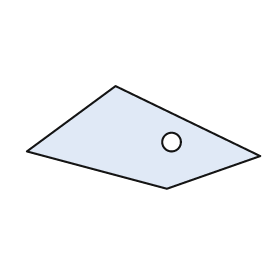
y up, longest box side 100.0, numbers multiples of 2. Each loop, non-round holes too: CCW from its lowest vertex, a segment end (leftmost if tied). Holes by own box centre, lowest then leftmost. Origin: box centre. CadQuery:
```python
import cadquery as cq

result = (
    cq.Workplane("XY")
    .moveTo(10.0, -22.0)
    .lineTo(50.0, -8.0)
    .lineTo(-12.0, 22.0)
    .lineTo(-50.0, -6.0)
    .close()
    .moveTo(12.0, -2.0)
    .circle(4.0)
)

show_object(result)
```